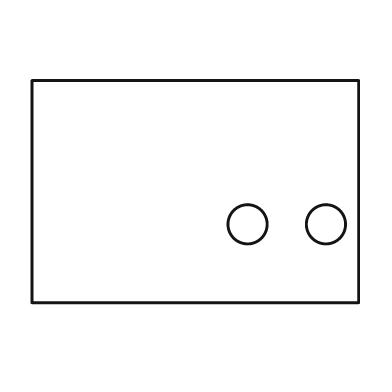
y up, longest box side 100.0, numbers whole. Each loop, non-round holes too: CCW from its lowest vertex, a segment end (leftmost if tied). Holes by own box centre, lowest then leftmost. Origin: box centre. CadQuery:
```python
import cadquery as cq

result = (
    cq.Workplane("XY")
    .moveTo(-50.0, -34.0)
    .lineTo(50.0, -34.0)
    .lineTo(50.0, 34.0)
    .lineTo(-50.0, 34.0)
    .close()
    .moveTo(16.0, -10.0)
    .circle(6.0)
    .moveTo(40.0, -10.0)
    .circle(6.0)
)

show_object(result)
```